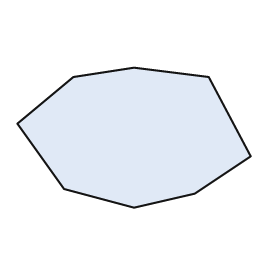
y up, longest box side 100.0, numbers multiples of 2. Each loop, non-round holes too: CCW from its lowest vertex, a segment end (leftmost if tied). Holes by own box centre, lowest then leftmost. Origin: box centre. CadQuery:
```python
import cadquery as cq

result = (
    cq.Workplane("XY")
    .moveTo(0.0, -30.0)
    .lineTo(26.0, -24.0)
    .lineTo(50.0, -8.0)
    .lineTo(32.0, 26.0)
    .lineTo(0.0, 30.0)
    .lineTo(-26.0, 26.0)
    .lineTo(-50.0, 6.0)
    .lineTo(-30.0, -22.0)
    .close()
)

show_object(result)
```